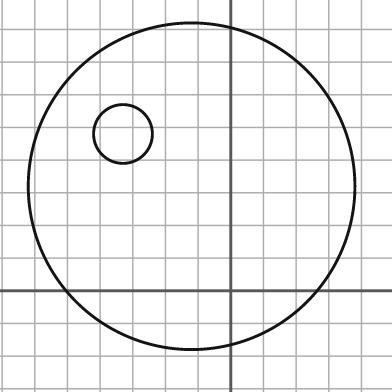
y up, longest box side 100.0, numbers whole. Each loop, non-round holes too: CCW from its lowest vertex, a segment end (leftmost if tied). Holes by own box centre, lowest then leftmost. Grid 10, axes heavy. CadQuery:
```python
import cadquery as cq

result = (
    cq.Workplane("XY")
    .moveTo(-12.0, 32.0)
    .circle(50.0)
    .moveTo(-33.0, 48.0)
    .circle(9.0)
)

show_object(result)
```